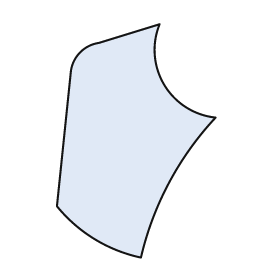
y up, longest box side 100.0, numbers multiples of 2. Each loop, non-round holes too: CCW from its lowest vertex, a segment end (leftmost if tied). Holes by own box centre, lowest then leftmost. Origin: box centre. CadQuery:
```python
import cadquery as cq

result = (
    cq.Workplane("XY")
    .moveTo(2.0, -50.0)
    .threePointArc((14.0, -18.0), (34.0, 10.0))
    .threePointArc((12.0, 24.0), (10.0, 50.0))
    .lineTo(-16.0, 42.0)
    .threePointArc((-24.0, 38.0), (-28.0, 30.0))
    .lineTo(-34.0, -28.0)
    .threePointArc((-18.0, -42.0), (2.0, -50.0))
    .close()
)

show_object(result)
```